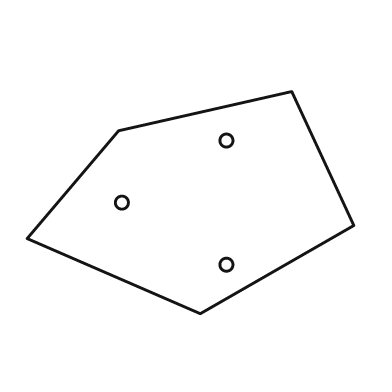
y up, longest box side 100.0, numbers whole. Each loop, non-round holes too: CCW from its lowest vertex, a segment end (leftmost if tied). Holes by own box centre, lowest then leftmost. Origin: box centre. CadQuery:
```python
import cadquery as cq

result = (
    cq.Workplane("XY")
    .moveTo(3.0, -34.0)
    .lineTo(50.0, -7.0)
    .lineTo(31.0, 34.0)
    .lineTo(-22.0, 22.0)
    .lineTo(-50.0, -11.0)
    .close()
    .moveTo(11.0, -19.0)
    .circle(2.0)
    .moveTo(-21.0, 0.0)
    .circle(2.0)
    .moveTo(11.0, 19.0)
    .circle(2.0)
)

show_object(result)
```